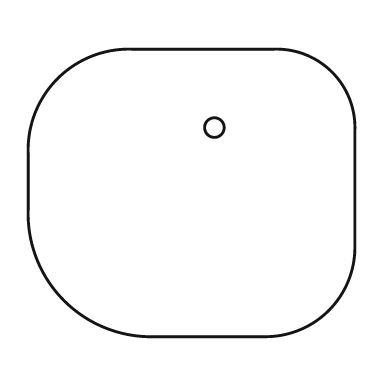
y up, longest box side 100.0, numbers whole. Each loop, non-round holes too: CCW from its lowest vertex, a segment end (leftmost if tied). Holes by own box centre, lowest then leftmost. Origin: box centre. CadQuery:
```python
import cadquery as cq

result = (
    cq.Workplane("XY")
    .moveTo(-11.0, -44.0)
    .lineTo(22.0, -44.0)
    .threePointArc((42.0, -36.0), (50.0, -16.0))
    .lineTo(50.0, 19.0)
    .threePointArc((43.0, 37.0), (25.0, 44.0))
    .lineTo(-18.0, 44.0)
    .threePointArc((-41.0, 35.0), (-50.0, 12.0))
    .lineTo(-50.0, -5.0)
    .threePointArc((-39.0, -33.0), (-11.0, -44.0))
    .close()
    .moveTo(7.0, 20.0)
    .circle(3.0)
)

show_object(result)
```